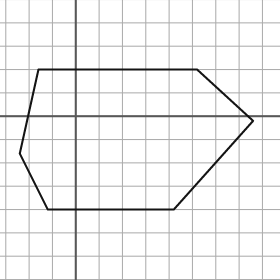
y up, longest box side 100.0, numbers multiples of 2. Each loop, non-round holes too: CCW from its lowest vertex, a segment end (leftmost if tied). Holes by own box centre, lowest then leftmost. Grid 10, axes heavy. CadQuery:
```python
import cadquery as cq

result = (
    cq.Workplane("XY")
    .moveTo(-12.0, -40.0)
    .lineTo(42.0, -40.0)
    .lineTo(76.0, -2.0)
    .lineTo(52.0, 20.0)
    .lineTo(-16.0, 20.0)
    .lineTo(-24.0, -16.0)
    .close()
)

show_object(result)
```